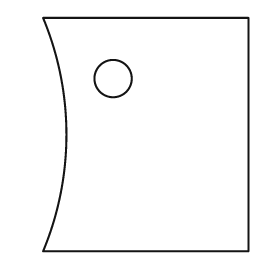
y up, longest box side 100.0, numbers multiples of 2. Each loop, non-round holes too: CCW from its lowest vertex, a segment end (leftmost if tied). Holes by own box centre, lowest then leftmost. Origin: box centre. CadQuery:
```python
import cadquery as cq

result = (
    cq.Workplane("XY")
    .moveTo(-44.0, -50.0)
    .lineTo(44.0, -50.0)
    .lineTo(44.0, 50.0)
    .lineTo(-44.0, 50.0)
    .threePointArc((-34.0, 0.0), (-44.0, -50.0))
    .close()
    .moveTo(-14.0, 24.0)
    .circle(8.0)
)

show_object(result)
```